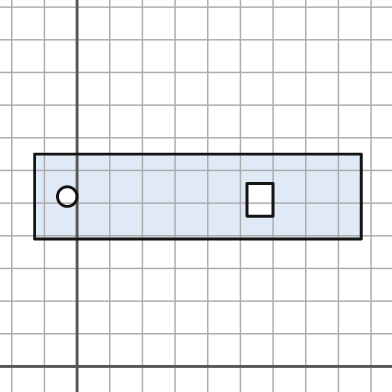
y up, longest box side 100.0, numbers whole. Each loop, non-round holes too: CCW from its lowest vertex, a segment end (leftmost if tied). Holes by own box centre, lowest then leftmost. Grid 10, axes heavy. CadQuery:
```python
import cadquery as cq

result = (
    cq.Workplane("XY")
    .moveTo(-13.0, 39.0)
    .lineTo(87.0, 39.0)
    .lineTo(87.0, 65.0)
    .lineTo(-13.0, 65.0)
    .close()
    .moveTo(52.0, 46.0)
    .lineTo(60.0, 46.0)
    .lineTo(60.0, 56.0)
    .lineTo(52.0, 56.0)
    .close()
    .moveTo(-3.0, 52.0)
    .circle(3.0)
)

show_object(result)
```